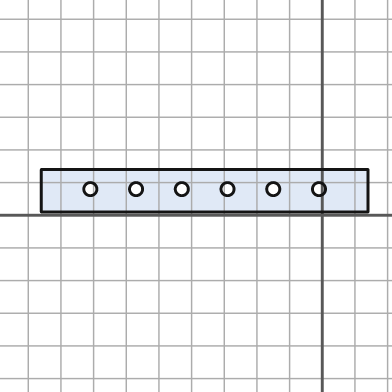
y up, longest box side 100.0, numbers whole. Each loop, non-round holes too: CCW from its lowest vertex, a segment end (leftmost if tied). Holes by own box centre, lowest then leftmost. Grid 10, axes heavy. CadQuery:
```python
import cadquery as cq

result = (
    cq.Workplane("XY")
    .moveTo(-86.0, 1.0)
    .lineTo(14.0, 1.0)
    .lineTo(14.0, 14.0)
    .lineTo(-86.0, 14.0)
    .close()
    .moveTo(-71.0, 8.0)
    .circle(2.0)
    .moveTo(-57.0, 8.0)
    .circle(2.0)
    .moveTo(-43.0, 8.0)
    .circle(2.0)
    .moveTo(-29.0, 8.0)
    .circle(2.0)
    .moveTo(-15.0, 8.0)
    .circle(2.0)
    .moveTo(-1.0, 8.0)
    .circle(2.0)
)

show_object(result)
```